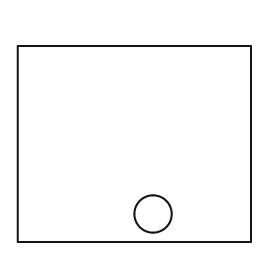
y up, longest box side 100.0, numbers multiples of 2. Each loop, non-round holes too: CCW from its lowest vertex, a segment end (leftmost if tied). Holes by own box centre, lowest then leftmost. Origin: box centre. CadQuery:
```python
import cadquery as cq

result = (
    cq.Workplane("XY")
    .moveTo(-50.0, -42.0)
    .lineTo(50.0, -42.0)
    .lineTo(50.0, 42.0)
    .lineTo(-50.0, 42.0)
    .close()
    .moveTo(8.0, -30.0)
    .circle(8.0)
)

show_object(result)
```